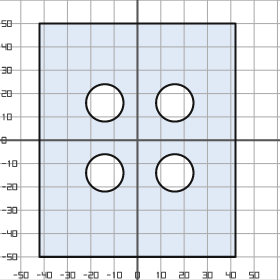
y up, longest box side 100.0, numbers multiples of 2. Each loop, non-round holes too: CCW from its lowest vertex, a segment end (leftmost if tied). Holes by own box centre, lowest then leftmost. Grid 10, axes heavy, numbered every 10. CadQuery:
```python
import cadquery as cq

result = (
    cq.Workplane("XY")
    .moveTo(-42.0, -50.0)
    .lineTo(42.0, -50.0)
    .lineTo(42.0, 50.0)
    .lineTo(-42.0, 50.0)
    .close()
    .moveTo(-14.0, -14.0)
    .circle(8.0)
    .moveTo(16.0, -14.0)
    .circle(8.0)
    .moveTo(-14.0, 16.0)
    .circle(8.0)
    .moveTo(16.0, 16.0)
    .circle(8.0)
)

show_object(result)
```